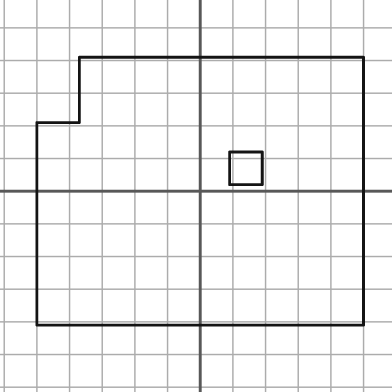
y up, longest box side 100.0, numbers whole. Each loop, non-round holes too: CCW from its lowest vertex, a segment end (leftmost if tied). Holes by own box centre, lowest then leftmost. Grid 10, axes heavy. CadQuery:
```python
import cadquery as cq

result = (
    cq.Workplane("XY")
    .moveTo(-50.0, -41.0)
    .lineTo(50.0, -41.0)
    .lineTo(50.0, 41.0)
    .lineTo(-37.0, 41.0)
    .lineTo(-37.0, 21.0)
    .lineTo(-50.0, 21.0)
    .close()
    .moveTo(9.0, 2.0)
    .lineTo(19.0, 2.0)
    .lineTo(19.0, 12.0)
    .lineTo(9.0, 12.0)
    .close()
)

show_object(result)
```